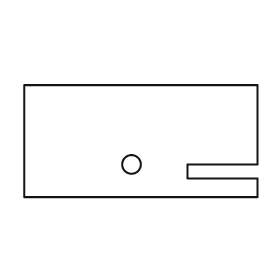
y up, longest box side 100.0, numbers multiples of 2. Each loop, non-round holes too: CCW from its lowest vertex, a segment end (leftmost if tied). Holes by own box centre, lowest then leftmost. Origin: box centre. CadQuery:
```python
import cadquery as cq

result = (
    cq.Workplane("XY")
    .moveTo(-50.0, -24.0)
    .lineTo(50.0, -24.0)
    .lineTo(50.0, -16.0)
    .lineTo(20.0, -16.0)
    .lineTo(20.0, -10.0)
    .lineTo(50.0, -10.0)
    .lineTo(50.0, 24.0)
    .lineTo(-50.0, 24.0)
    .close()
    .moveTo(-4.0, -10.0)
    .circle(4.0)
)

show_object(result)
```